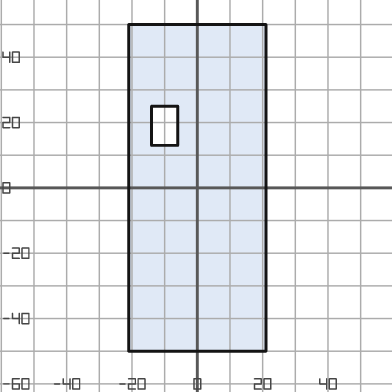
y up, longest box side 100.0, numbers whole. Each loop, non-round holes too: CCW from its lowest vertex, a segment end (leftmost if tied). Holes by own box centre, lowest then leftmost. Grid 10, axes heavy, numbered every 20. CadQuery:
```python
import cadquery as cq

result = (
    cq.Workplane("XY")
    .moveTo(-21.0, -50.0)
    .lineTo(21.0, -50.0)
    .lineTo(21.0, 50.0)
    .lineTo(-21.0, 50.0)
    .close()
    .moveTo(-14.0, 13.0)
    .lineTo(-6.0, 13.0)
    .lineTo(-6.0, 25.0)
    .lineTo(-14.0, 25.0)
    .close()
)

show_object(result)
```